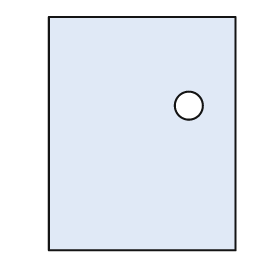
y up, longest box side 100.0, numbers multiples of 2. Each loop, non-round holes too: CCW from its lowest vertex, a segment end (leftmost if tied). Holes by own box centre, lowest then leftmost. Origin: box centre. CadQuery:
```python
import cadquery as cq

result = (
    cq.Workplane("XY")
    .moveTo(-40.0, -50.0)
    .lineTo(40.0, -50.0)
    .lineTo(40.0, 50.0)
    .lineTo(-40.0, 50.0)
    .close()
    .moveTo(20.0, 12.0)
    .circle(6.0)
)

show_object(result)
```